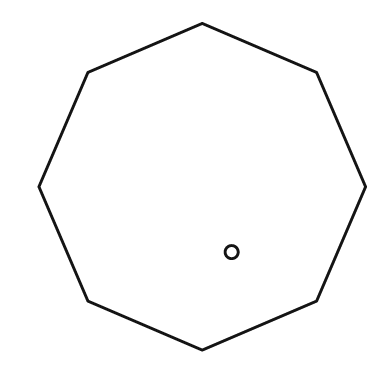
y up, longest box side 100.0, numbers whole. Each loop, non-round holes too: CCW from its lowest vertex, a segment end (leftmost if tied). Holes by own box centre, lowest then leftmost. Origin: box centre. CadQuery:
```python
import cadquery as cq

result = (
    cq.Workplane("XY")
    .moveTo(0.0, -50.0)
    .lineTo(35.0, -35.0)
    .lineTo(50.0, 0.0)
    .lineTo(35.0, 35.0)
    .lineTo(0.0, 50.0)
    .lineTo(-35.0, 35.0)
    .lineTo(-50.0, 0.0)
    .lineTo(-35.0, -35.0)
    .close()
    .moveTo(9.0, -20.0)
    .circle(2.0)
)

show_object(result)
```